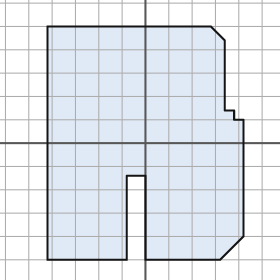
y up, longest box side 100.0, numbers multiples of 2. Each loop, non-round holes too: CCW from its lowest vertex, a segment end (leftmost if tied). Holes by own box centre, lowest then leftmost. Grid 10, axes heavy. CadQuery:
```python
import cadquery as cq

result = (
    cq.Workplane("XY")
    .moveTo(-42.0, -50.0)
    .lineTo(-8.0, -50.0)
    .lineTo(-8.0, -14.0)
    .lineTo(0.0, -14.0)
    .lineTo(0.0, -50.0)
    .lineTo(32.0, -50.0)
    .lineTo(42.0, -40.0)
    .lineTo(42.0, 10.0)
    .lineTo(38.0, 10.0)
    .lineTo(38.0, 14.0)
    .lineTo(34.0, 14.0)
    .lineTo(34.0, 44.0)
    .lineTo(28.0, 50.0)
    .lineTo(-42.0, 50.0)
    .close()
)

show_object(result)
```